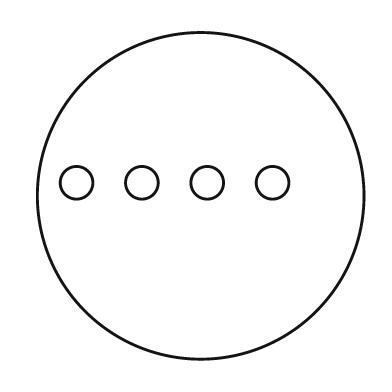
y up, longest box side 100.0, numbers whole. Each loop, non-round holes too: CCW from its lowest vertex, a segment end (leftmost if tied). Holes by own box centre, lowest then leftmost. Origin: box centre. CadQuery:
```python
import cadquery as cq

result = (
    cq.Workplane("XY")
    .moveTo(0.0, 0.0)
    .circle(50.0)
    .moveTo(-38.0, 4.0)
    .circle(5.0)
    .moveTo(-18.0, 4.0)
    .circle(5.0)
    .moveTo(2.0, 4.0)
    .circle(5.0)
    .moveTo(22.0, 4.0)
    .circle(5.0)
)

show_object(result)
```